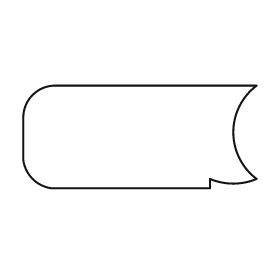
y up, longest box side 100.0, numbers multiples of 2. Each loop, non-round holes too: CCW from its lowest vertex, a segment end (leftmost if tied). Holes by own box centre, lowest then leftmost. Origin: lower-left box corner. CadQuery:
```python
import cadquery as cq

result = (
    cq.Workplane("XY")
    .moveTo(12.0, 0.0)
    .lineTo(80.0, 0.0)
    .lineTo(80.0, 4.0)
    .threePointArc((90.0, 2.0), (100.0, 4.0))
    .threePointArc((90.0, 24.0), (100.0, 44.0))
    .lineTo(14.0, 44.0)
    .threePointArc((4.0, 40.0), (0.0, 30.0))
    .lineTo(0.0, 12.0)
    .threePointArc((4.0, 4.0), (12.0, 0.0))
    .close()
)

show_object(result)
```